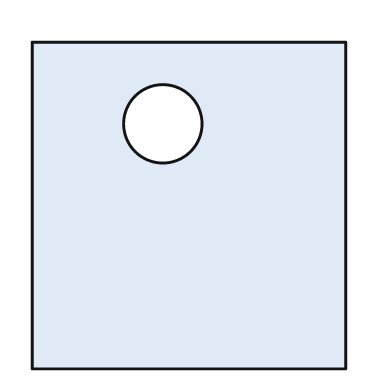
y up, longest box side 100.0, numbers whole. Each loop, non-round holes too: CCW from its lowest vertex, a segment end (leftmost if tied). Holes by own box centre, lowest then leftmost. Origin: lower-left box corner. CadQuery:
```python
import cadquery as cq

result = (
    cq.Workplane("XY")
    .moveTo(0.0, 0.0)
    .lineTo(96.0, 0.0)
    .lineTo(96.0, 100.0)
    .lineTo(0.0, 100.0)
    .close()
    .moveTo(40.0, 75.0)
    .circle(12.0)
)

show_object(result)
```